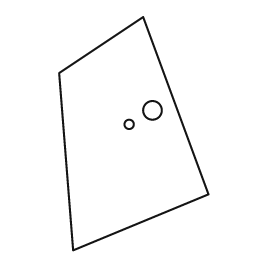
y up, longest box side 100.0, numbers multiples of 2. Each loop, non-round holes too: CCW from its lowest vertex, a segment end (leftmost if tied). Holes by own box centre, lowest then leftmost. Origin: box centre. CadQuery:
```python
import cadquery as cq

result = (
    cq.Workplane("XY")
    .moveTo(-26.0, -50.0)
    .lineTo(32.0, -26.0)
    .lineTo(4.0, 50.0)
    .lineTo(-32.0, 26.0)
    .close()
    .moveTo(-2.0, 4.0)
    .circle(2.0)
    .moveTo(8.0, 10.0)
    .circle(4.0)
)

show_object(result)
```